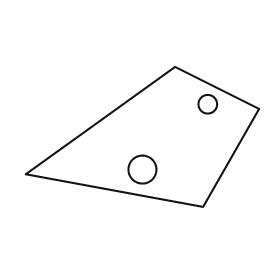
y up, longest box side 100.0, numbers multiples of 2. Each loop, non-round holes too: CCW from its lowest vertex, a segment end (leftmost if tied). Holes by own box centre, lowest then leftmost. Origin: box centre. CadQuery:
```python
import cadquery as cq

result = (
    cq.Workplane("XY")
    .moveTo(26.0, -30.0)
    .lineTo(50.0, 12.0)
    .lineTo(14.0, 30.0)
    .lineTo(-50.0, -16.0)
    .close()
    .moveTo(0.0, -14.0)
    .circle(6.0)
    .moveTo(28.0, 14.0)
    .circle(4.0)
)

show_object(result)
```